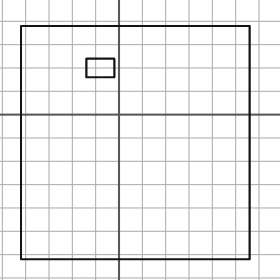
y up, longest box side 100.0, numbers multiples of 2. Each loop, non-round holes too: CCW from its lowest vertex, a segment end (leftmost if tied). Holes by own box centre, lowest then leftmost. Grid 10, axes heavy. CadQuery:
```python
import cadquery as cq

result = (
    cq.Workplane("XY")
    .moveTo(-42.0, -62.0)
    .lineTo(56.0, -62.0)
    .lineTo(56.0, 38.0)
    .lineTo(-42.0, 38.0)
    .close()
    .moveTo(-14.0, 16.0)
    .lineTo(-2.0, 16.0)
    .lineTo(-2.0, 24.0)
    .lineTo(-14.0, 24.0)
    .close()
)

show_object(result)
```